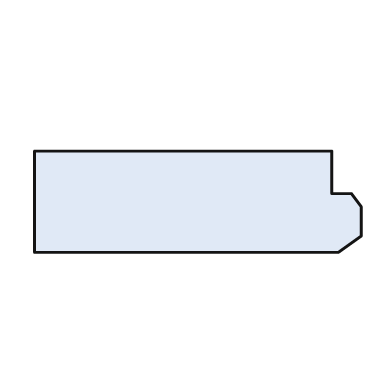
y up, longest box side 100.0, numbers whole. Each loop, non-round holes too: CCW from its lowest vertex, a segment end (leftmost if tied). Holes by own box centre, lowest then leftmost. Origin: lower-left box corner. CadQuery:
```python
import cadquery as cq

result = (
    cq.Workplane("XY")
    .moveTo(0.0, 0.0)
    .lineTo(93.0, 0.0)
    .lineTo(100.0, 5.0)
    .lineTo(100.0, 14.0)
    .lineTo(97.0, 18.0)
    .lineTo(91.0, 18.0)
    .lineTo(91.0, 31.0)
    .lineTo(0.0, 31.0)
    .close()
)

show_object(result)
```